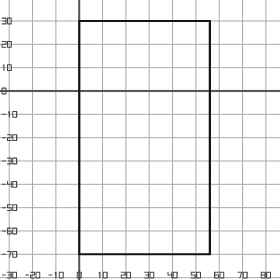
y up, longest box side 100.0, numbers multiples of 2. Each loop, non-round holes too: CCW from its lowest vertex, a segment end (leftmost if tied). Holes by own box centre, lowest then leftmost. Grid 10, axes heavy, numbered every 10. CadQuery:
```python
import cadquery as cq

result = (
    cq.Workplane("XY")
    .moveTo(0.0, -70.0)
    .lineTo(56.0, -70.0)
    .lineTo(56.0, 30.0)
    .lineTo(0.0, 30.0)
    .close()
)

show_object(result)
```